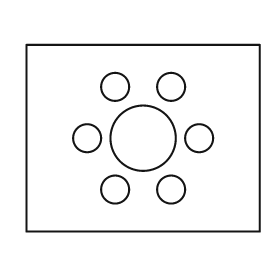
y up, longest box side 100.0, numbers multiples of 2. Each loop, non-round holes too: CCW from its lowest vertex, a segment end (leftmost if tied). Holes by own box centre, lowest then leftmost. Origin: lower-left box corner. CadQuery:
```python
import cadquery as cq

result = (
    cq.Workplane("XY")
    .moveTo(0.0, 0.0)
    .lineTo(100.0, 0.0)
    .lineTo(100.0, 80.0)
    .lineTo(0.0, 80.0)
    .close()
    .moveTo(38.0, 18.0)
    .circle(6.0)
    .moveTo(62.0, 18.0)
    .circle(6.0)
    .moveTo(26.0, 40.0)
    .circle(6.0)
    .moveTo(50.0, 40.0)
    .circle(14.0)
    .moveTo(74.0, 40.0)
    .circle(6.0)
    .moveTo(38.0, 62.0)
    .circle(6.0)
    .moveTo(62.0, 62.0)
    .circle(6.0)
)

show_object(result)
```